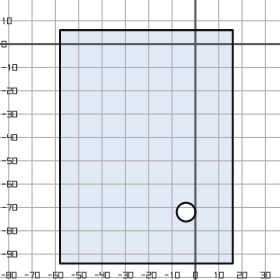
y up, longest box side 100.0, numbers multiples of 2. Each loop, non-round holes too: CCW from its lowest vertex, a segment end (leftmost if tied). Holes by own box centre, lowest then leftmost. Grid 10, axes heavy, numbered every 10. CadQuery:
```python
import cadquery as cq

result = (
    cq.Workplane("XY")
    .moveTo(-58.0, -94.0)
    .lineTo(16.0, -94.0)
    .lineTo(16.0, 6.0)
    .lineTo(-58.0, 6.0)
    .close()
    .moveTo(-4.0, -72.0)
    .circle(4.0)
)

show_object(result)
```